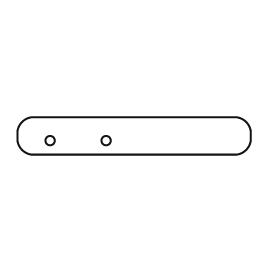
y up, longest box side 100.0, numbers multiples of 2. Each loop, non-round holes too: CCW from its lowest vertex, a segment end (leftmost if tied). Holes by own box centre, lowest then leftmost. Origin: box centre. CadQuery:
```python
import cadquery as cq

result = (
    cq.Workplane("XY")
    .moveTo(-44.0, -8.0)
    .lineTo(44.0, -8.0)
    .threePointArc((48.0, -6.0), (50.0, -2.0))
    .lineTo(50.0, 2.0)
    .threePointArc((48.0, 6.0), (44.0, 8.0))
    .lineTo(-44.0, 8.0)
    .threePointArc((-48.0, 6.0), (-50.0, 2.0))
    .lineTo(-50.0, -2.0)
    .threePointArc((-48.0, -6.0), (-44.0, -8.0))
    .close()
    .moveTo(-36.0, -2.0)
    .circle(2.0)
    .moveTo(-12.0, -2.0)
    .circle(2.0)
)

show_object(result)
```